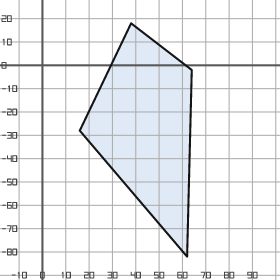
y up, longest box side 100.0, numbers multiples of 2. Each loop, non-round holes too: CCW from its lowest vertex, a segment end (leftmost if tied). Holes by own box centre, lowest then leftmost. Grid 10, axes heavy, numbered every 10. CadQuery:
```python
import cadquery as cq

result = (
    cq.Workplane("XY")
    .moveTo(62.0, -82.0)
    .lineTo(64.0, -2.0)
    .lineTo(38.0, 18.0)
    .lineTo(16.0, -28.0)
    .close()
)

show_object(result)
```